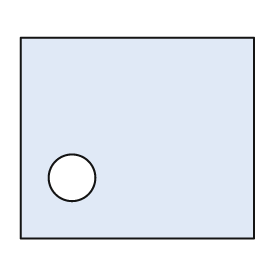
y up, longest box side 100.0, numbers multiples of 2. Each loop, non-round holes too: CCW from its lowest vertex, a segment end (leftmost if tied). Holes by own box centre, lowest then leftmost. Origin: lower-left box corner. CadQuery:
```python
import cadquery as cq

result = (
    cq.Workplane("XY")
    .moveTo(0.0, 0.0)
    .lineTo(100.0, 0.0)
    .lineTo(100.0, 86.0)
    .lineTo(0.0, 86.0)
    .close()
    .moveTo(22.0, 26.0)
    .circle(10.0)
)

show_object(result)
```